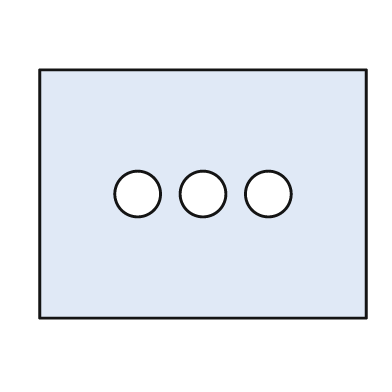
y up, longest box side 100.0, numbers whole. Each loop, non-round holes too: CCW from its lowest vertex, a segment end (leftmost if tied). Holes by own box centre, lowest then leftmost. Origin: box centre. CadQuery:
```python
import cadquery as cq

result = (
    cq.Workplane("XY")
    .moveTo(-50.0, -38.0)
    .lineTo(50.0, -38.0)
    .lineTo(50.0, 38.0)
    .lineTo(-50.0, 38.0)
    .close()
    .moveTo(-20.0, 0.0)
    .circle(7.0)
    .moveTo(0.0, 0.0)
    .circle(7.0)
    .moveTo(20.0, 0.0)
    .circle(7.0)
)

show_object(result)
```